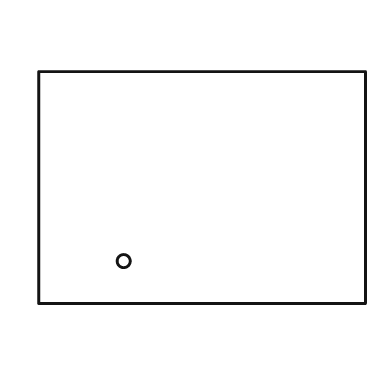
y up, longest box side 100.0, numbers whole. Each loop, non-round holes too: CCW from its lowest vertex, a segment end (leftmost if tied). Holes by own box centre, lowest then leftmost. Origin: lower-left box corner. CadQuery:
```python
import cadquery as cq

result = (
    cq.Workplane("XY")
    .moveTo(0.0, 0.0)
    .lineTo(100.0, 0.0)
    .lineTo(100.0, 71.0)
    .lineTo(0.0, 71.0)
    .close()
    .moveTo(26.0, 13.0)
    .circle(2.0)
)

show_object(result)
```